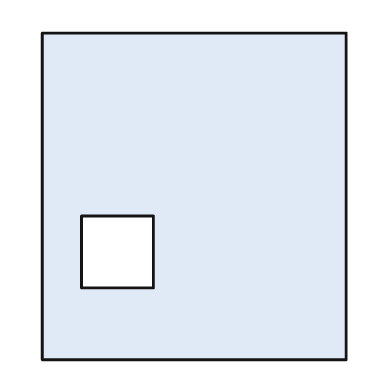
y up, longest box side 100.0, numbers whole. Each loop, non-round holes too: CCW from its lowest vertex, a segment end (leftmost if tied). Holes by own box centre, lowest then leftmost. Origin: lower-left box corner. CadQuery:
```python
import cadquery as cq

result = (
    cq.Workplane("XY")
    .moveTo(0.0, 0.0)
    .lineTo(93.0, 0.0)
    .lineTo(93.0, 100.0)
    .lineTo(0.0, 100.0)
    .close()
    .moveTo(12.0, 22.0)
    .lineTo(34.0, 22.0)
    .lineTo(34.0, 44.0)
    .lineTo(12.0, 44.0)
    .close()
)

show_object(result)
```